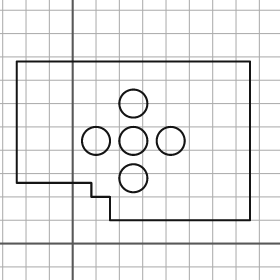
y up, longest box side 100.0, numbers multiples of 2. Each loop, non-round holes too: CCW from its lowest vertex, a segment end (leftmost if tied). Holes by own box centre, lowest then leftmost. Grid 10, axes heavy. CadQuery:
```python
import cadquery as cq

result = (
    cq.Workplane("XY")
    .moveTo(16.0, 10.0)
    .lineTo(76.0, 10.0)
    .lineTo(76.0, 78.0)
    .lineTo(-24.0, 78.0)
    .lineTo(-24.0, 26.0)
    .lineTo(8.0, 26.0)
    .lineTo(8.0, 20.0)
    .lineTo(16.0, 20.0)
    .close()
    .moveTo(26.0, 28.0)
    .circle(6.0)
    .moveTo(10.0, 44.0)
    .circle(6.0)
    .moveTo(26.0, 44.0)
    .circle(6.0)
    .moveTo(42.0, 44.0)
    .circle(6.0)
    .moveTo(26.0, 60.0)
    .circle(6.0)
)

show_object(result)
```